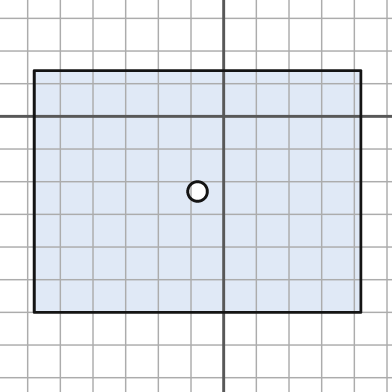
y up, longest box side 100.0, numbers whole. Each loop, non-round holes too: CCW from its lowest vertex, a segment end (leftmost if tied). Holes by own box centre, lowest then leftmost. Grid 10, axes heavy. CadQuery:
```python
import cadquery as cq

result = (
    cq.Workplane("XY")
    .moveTo(-58.0, -60.0)
    .lineTo(42.0, -60.0)
    .lineTo(42.0, 14.0)
    .lineTo(-58.0, 14.0)
    .close()
    .moveTo(-8.0, -23.0)
    .circle(3.0)
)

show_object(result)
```